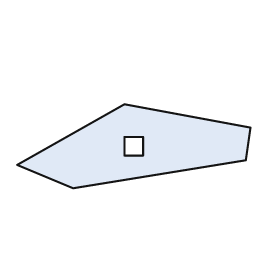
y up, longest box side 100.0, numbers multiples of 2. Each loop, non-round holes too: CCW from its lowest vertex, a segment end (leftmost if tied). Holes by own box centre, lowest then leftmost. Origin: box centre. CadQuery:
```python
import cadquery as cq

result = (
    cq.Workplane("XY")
    .moveTo(-26.0, -18.0)
    .lineTo(48.0, -6.0)
    .lineTo(50.0, 8.0)
    .lineTo(-4.0, 18.0)
    .lineTo(-50.0, -8.0)
    .close()
    .moveTo(-4.0, -4.0)
    .lineTo(4.0, -4.0)
    .lineTo(4.0, 4.0)
    .lineTo(-4.0, 4.0)
    .close()
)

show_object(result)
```